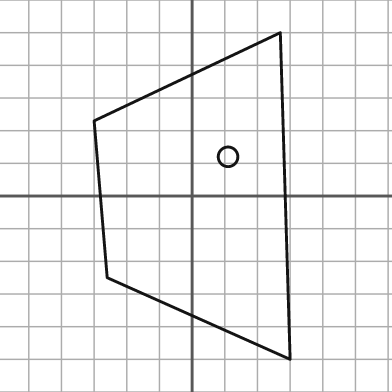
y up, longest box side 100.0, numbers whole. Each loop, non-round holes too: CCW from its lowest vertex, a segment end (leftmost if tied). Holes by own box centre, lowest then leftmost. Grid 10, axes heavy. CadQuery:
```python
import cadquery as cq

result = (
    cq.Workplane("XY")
    .moveTo(30.0, -50.0)
    .lineTo(27.0, 50.0)
    .lineTo(-30.0, 23.0)
    .lineTo(-26.0, -25.0)
    .close()
    .moveTo(11.0, 12.0)
    .circle(3.0)
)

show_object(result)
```